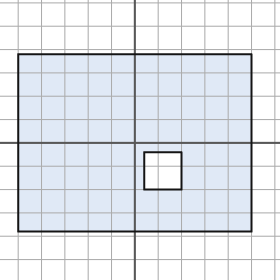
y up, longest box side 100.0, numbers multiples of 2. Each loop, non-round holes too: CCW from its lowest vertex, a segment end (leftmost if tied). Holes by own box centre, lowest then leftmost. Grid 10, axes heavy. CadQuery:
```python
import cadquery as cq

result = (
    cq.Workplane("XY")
    .moveTo(-50.0, -38.0)
    .lineTo(50.0, -38.0)
    .lineTo(50.0, 38.0)
    .lineTo(-50.0, 38.0)
    .close()
    .moveTo(4.0, -20.0)
    .lineTo(20.0, -20.0)
    .lineTo(20.0, -4.0)
    .lineTo(4.0, -4.0)
    .close()
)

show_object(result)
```